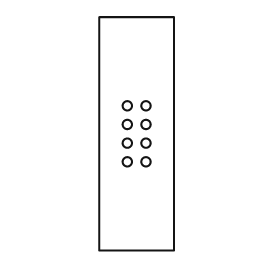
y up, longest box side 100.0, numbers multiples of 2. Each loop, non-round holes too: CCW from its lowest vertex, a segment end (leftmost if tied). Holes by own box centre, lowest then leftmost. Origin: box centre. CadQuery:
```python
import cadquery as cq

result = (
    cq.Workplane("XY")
    .moveTo(-16.0, -50.0)
    .lineTo(16.0, -50.0)
    .lineTo(16.0, 50.0)
    .lineTo(-16.0, 50.0)
    .close()
    .moveTo(-4.0, -12.0)
    .circle(2.0)
    .moveTo(4.0, -12.0)
    .circle(2.0)
    .moveTo(-4.0, -4.0)
    .circle(2.0)
    .moveTo(4.0, -4.0)
    .circle(2.0)
    .moveTo(-4.0, 4.0)
    .circle(2.0)
    .moveTo(4.0, 4.0)
    .circle(2.0)
    .moveTo(-4.0, 12.0)
    .circle(2.0)
    .moveTo(4.0, 12.0)
    .circle(2.0)
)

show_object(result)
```